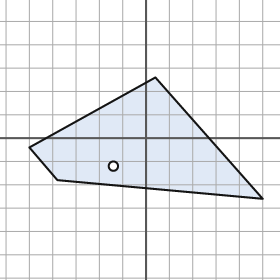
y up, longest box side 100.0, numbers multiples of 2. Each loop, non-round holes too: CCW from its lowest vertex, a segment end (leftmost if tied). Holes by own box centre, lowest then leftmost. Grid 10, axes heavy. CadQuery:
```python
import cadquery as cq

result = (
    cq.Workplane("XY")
    .moveTo(50.0, -26.0)
    .lineTo(4.0, 26.0)
    .lineTo(-50.0, -4.0)
    .lineTo(-38.0, -18.0)
    .close()
    .moveTo(-14.0, -12.0)
    .circle(2.0)
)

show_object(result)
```